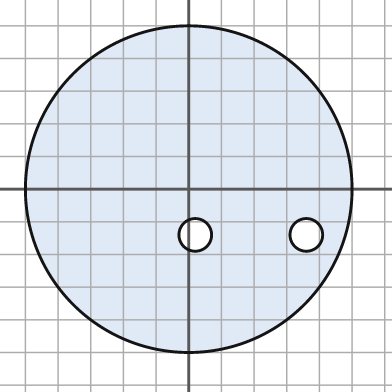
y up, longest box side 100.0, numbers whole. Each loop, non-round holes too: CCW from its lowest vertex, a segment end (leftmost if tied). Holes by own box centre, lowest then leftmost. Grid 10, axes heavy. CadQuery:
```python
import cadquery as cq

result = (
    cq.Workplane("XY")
    .moveTo(0.0, 0.0)
    .circle(50.0)
    .moveTo(2.0, -14.0)
    .circle(5.0)
    .moveTo(36.0, -14.0)
    .circle(5.0)
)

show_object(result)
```